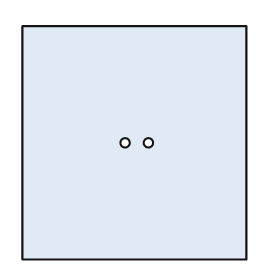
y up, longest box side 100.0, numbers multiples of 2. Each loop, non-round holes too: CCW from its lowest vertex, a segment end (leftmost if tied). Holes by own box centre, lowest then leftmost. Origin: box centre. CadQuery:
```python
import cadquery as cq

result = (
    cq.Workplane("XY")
    .moveTo(-48.0, -50.0)
    .lineTo(48.0, -50.0)
    .lineTo(48.0, 50.0)
    .lineTo(-48.0, 50.0)
    .close()
    .moveTo(-4.0, 0.0)
    .circle(2.0)
    .moveTo(6.0, 0.0)
    .circle(2.0)
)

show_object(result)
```